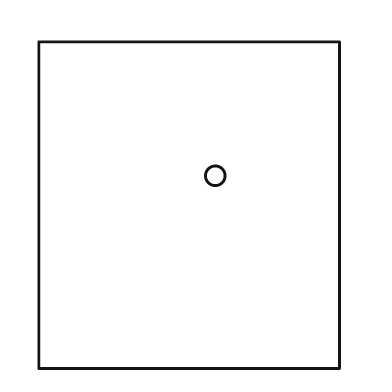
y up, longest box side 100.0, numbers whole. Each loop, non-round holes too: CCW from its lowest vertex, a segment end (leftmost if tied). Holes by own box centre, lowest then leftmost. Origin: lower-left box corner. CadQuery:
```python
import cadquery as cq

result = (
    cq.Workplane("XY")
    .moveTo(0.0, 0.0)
    .lineTo(92.0, 0.0)
    .lineTo(92.0, 100.0)
    .lineTo(0.0, 100.0)
    .close()
    .moveTo(54.0, 59.0)
    .circle(3.0)
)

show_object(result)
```